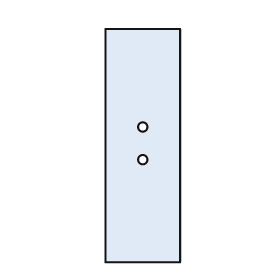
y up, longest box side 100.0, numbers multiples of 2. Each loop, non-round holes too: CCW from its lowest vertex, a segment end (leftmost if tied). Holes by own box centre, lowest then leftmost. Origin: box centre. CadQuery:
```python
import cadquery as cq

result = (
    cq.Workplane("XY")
    .moveTo(-16.0, -50.0)
    .lineTo(16.0, -50.0)
    .lineTo(16.0, 50.0)
    .lineTo(-16.0, 50.0)
    .close()
    .moveTo(0.0, -6.0)
    .circle(2.0)
    .moveTo(0.0, 8.0)
    .circle(2.0)
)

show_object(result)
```